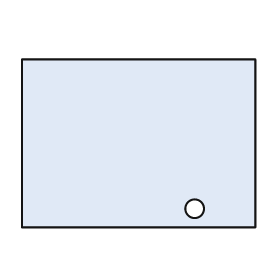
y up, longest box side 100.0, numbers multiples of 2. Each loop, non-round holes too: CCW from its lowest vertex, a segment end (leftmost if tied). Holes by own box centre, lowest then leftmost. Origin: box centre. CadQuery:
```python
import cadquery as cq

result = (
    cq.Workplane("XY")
    .moveTo(-50.0, -36.0)
    .lineTo(50.0, -36.0)
    .lineTo(50.0, 36.0)
    .lineTo(-50.0, 36.0)
    .close()
    .moveTo(24.0, -28.0)
    .circle(4.0)
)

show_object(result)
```